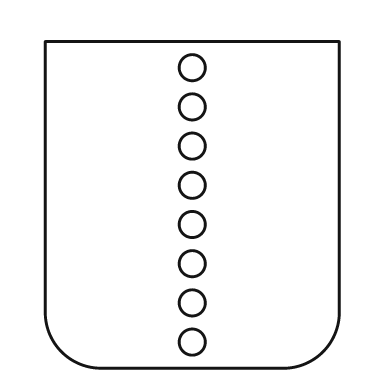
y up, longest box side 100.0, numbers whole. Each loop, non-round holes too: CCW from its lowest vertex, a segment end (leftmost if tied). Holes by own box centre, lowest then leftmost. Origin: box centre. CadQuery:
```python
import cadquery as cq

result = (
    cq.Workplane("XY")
    .moveTo(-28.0, -50.0)
    .lineTo(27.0, -50.0)
    .threePointArc((40.0, -45.0), (45.0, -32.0))
    .lineTo(45.0, 50.0)
    .lineTo(-45.0, 50.0)
    .lineTo(-45.0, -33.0)
    .threePointArc((-40.0, -45.0), (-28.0, -50.0))
    .close()
    .moveTo(0.0, -42.0)
    .circle(4.0)
    .moveTo(0.0, -30.0)
    .circle(4.0)
    .moveTo(0.0, -18.0)
    .circle(4.0)
    .moveTo(0.0, -6.0)
    .circle(4.0)
    .moveTo(0.0, 6.0)
    .circle(4.0)
    .moveTo(0.0, 18.0)
    .circle(4.0)
    .moveTo(0.0, 30.0)
    .circle(4.0)
    .moveTo(0.0, 42.0)
    .circle(4.0)
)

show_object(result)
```